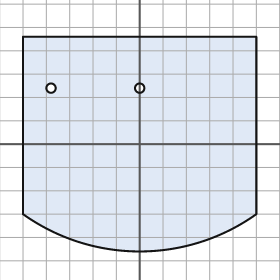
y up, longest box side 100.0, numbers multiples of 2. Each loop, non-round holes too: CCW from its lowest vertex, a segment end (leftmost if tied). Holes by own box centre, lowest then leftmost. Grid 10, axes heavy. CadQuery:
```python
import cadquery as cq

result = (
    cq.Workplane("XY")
    .moveTo(-50.0, -30.0)
    .threePointArc((0.0, -46.0), (50.0, -30.0))
    .lineTo(50.0, 46.0)
    .lineTo(-50.0, 46.0)
    .close()
    .moveTo(-38.0, 24.0)
    .circle(2.0)
    .moveTo(0.0, 24.0)
    .circle(2.0)
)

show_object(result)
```